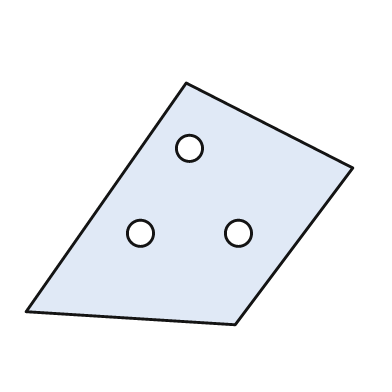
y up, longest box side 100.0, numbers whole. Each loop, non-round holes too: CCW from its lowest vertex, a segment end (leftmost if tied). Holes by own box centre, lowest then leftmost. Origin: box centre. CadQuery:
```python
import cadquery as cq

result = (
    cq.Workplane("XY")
    .moveTo(14.0, -37.0)
    .lineTo(50.0, 11.0)
    .lineTo(-1.0, 37.0)
    .lineTo(-50.0, -33.0)
    .close()
    .moveTo(-15.0, -9.0)
    .circle(4.0)
    .moveTo(15.0, -9.0)
    .circle(4.0)
    .moveTo(0.0, 17.0)
    .circle(4.0)
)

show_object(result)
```